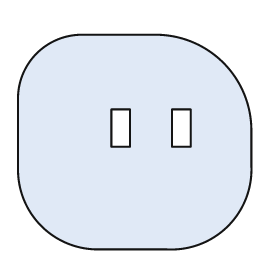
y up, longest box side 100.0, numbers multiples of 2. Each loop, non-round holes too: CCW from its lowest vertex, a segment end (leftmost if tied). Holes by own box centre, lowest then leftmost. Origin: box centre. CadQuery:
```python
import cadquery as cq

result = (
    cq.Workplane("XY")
    .moveTo(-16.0, -46.0)
    .lineTo(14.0, -46.0)
    .threePointArc((40.0, -36.0), (50.0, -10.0))
    .lineTo(50.0, 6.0)
    .threePointArc((38.0, 34.0), (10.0, 46.0))
    .lineTo(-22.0, 46.0)
    .threePointArc((-42.0, 38.0), (-50.0, 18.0))
    .lineTo(-50.0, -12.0)
    .threePointArc((-40.0, -36.0), (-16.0, -46.0))
    .close()
    .moveTo(-10.0, -2.0)
    .lineTo(-2.0, -2.0)
    .lineTo(-2.0, 14.0)
    .lineTo(-10.0, 14.0)
    .close()
    .moveTo(16.0, -2.0)
    .lineTo(24.0, -2.0)
    .lineTo(24.0, 14.0)
    .lineTo(16.0, 14.0)
    .close()
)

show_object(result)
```